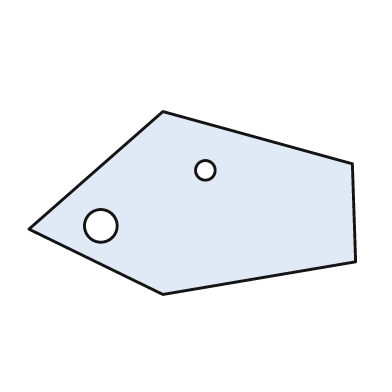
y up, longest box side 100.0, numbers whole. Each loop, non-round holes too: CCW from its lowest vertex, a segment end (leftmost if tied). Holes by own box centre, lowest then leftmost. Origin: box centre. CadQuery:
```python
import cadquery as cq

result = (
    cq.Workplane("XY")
    .moveTo(-9.0, -28.0)
    .lineTo(50.0, -18.0)
    .lineTo(49.0, 12.0)
    .lineTo(-9.0, 28.0)
    .lineTo(-50.0, -8.0)
    .close()
    .moveTo(-28.0, -7.0)
    .circle(5.0)
    .moveTo(4.0, 10.0)
    .circle(3.0)
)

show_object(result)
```